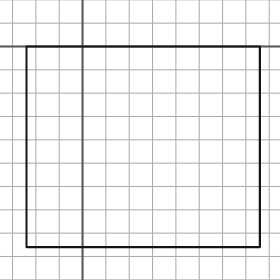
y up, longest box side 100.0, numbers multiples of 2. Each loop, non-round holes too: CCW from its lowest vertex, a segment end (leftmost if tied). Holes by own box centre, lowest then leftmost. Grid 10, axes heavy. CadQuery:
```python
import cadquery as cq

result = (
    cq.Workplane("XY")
    .moveTo(-24.0, -86.0)
    .lineTo(76.0, -86.0)
    .lineTo(76.0, 0.0)
    .lineTo(-24.0, 0.0)
    .close()
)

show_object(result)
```